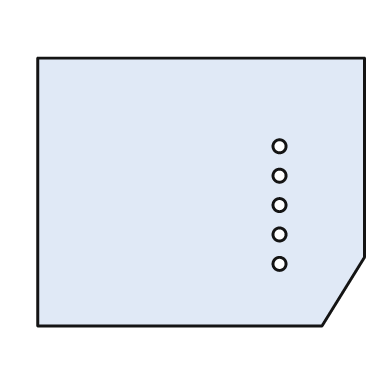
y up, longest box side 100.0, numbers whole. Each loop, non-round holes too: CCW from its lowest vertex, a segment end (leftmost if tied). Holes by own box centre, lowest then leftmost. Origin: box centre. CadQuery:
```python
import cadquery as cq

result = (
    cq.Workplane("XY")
    .moveTo(-50.0, -41.0)
    .lineTo(37.0, -41.0)
    .lineTo(50.0, -20.0)
    .lineTo(50.0, 41.0)
    .lineTo(-50.0, 41.0)
    .close()
    .moveTo(24.0, -22.0)
    .circle(2.0)
    .moveTo(24.0, -13.0)
    .circle(2.0)
    .moveTo(24.0, -4.0)
    .circle(2.0)
    .moveTo(24.0, 5.0)
    .circle(2.0)
    .moveTo(24.0, 14.0)
    .circle(2.0)
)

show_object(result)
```